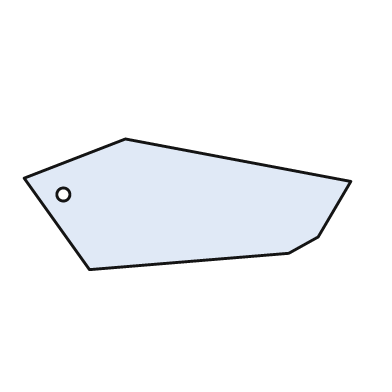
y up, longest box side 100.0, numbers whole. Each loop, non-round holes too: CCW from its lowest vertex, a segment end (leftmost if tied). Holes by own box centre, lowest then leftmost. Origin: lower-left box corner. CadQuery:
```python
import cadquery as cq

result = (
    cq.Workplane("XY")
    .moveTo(20.0, 0.0)
    .lineTo(81.0, 5.0)
    .lineTo(90.0, 10.0)
    .lineTo(100.0, 27.0)
    .lineTo(31.0, 40.0)
    .lineTo(0.0, 28.0)
    .close()
    .moveTo(12.0, 23.0)
    .circle(2.0)
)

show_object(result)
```